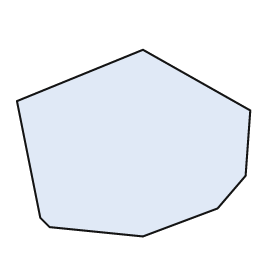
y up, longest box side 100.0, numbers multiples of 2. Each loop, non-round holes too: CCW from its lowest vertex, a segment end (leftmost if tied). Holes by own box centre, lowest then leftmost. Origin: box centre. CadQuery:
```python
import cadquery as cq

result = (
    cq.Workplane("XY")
    .moveTo(4.0, -40.0)
    .lineTo(36.0, -28.0)
    .lineTo(48.0, -14.0)
    .lineTo(50.0, 14.0)
    .lineTo(4.0, 40.0)
    .lineTo(-50.0, 18.0)
    .lineTo(-40.0, -32.0)
    .lineTo(-36.0, -36.0)
    .close()
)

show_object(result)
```